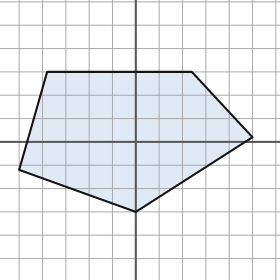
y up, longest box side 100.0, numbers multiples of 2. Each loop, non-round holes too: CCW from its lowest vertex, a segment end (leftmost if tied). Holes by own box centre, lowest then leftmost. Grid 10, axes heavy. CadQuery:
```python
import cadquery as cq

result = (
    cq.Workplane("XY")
    .moveTo(0.0, -30.0)
    .lineTo(50.0, 2.0)
    .lineTo(24.0, 30.0)
    .lineTo(-38.0, 30.0)
    .lineTo(-50.0, -12.0)
    .close()
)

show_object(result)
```